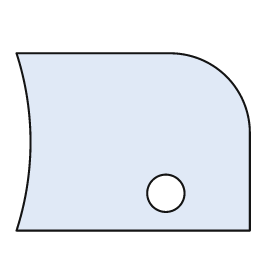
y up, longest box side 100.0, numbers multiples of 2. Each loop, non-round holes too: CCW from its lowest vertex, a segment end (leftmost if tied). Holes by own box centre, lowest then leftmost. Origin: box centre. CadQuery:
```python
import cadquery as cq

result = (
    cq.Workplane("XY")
    .moveTo(-50.0, -38.0)
    .lineTo(50.0, -38.0)
    .lineTo(50.0, 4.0)
    .threePointArc((40.0, 28.0), (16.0, 38.0))
    .lineTo(-50.0, 38.0)
    .threePointArc((-44.0, 0.0), (-50.0, -38.0))
    .close()
    .moveTo(14.0, -22.0)
    .circle(8.0)
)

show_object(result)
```